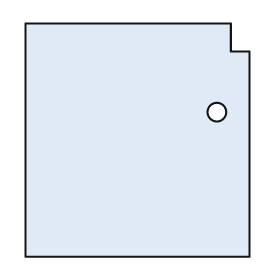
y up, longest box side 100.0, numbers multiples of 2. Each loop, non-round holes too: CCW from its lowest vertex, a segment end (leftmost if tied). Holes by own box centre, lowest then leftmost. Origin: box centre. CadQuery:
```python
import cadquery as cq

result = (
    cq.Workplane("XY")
    .moveTo(-48.0, -50.0)
    .lineTo(48.0, -50.0)
    .lineTo(48.0, 38.0)
    .lineTo(40.0, 38.0)
    .lineTo(40.0, 50.0)
    .lineTo(-48.0, 50.0)
    .close()
    .moveTo(34.0, 12.0)
    .circle(4.0)
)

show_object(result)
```